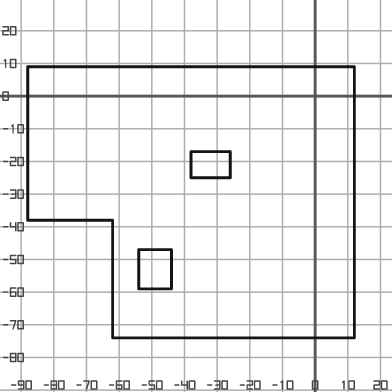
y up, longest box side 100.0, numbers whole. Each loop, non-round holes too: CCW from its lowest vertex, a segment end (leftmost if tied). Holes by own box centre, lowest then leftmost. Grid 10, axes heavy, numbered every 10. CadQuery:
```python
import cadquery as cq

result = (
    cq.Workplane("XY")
    .moveTo(-62.0, -74.0)
    .lineTo(12.0, -74.0)
    .lineTo(12.0, 9.0)
    .lineTo(-88.0, 9.0)
    .lineTo(-88.0, -38.0)
    .lineTo(-62.0, -38.0)
    .close()
    .moveTo(-54.0, -59.0)
    .lineTo(-44.0, -59.0)
    .lineTo(-44.0, -47.0)
    .lineTo(-54.0, -47.0)
    .close()
    .moveTo(-38.0, -25.0)
    .lineTo(-26.0, -25.0)
    .lineTo(-26.0, -17.0)
    .lineTo(-38.0, -17.0)
    .close()
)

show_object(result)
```